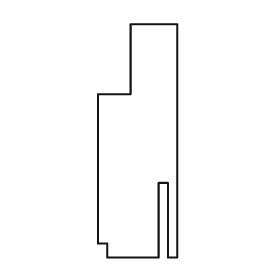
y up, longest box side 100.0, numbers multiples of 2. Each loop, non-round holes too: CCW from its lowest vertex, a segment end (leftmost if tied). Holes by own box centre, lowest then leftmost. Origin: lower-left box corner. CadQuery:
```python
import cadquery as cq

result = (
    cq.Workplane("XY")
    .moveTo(4.0, 0.0)
    .lineTo(26.0, 0.0)
    .lineTo(26.0, 32.0)
    .lineTo(30.0, 32.0)
    .lineTo(30.0, 0.0)
    .lineTo(34.0, 0.0)
    .lineTo(34.0, 100.0)
    .lineTo(14.0, 100.0)
    .lineTo(14.0, 70.0)
    .lineTo(0.0, 70.0)
    .lineTo(0.0, 6.0)
    .lineTo(4.0, 6.0)
    .close()
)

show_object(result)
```